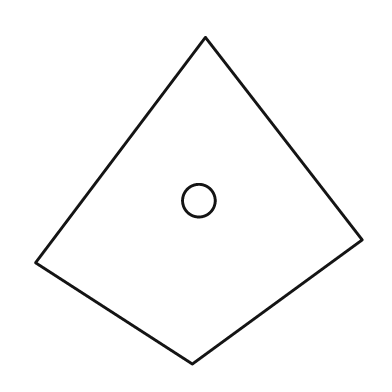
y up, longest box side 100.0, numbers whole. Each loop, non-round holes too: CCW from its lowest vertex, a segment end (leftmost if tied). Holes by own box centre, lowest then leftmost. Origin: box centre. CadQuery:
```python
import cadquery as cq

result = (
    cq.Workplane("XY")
    .moveTo(-2.0, -50.0)
    .lineTo(50.0, -12.0)
    .lineTo(2.0, 50.0)
    .lineTo(-50.0, -19.0)
    .close()
    .moveTo(0.0, 0.0)
    .circle(5.0)
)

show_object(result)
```